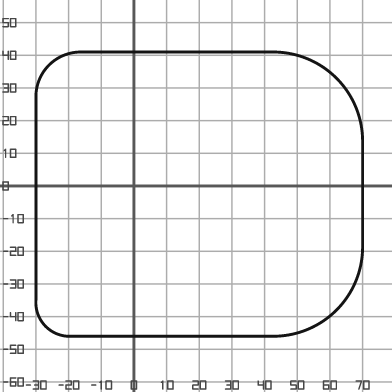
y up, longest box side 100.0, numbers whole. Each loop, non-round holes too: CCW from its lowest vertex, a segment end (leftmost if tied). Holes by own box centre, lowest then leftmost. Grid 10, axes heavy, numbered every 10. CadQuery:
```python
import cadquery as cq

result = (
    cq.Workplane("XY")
    .moveTo(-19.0, -46.0)
    .lineTo(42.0, -46.0)
    .threePointArc((62.0, -38.0), (70.0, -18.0))
    .lineTo(70.0, 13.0)
    .threePointArc((62.0, 33.0), (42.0, 41.0))
    .lineTo(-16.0, 41.0)
    .threePointArc((-26.0, 37.0), (-30.0, 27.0))
    .lineTo(-30.0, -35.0)
    .threePointArc((-27.0, -43.0), (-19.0, -46.0))
    .close()
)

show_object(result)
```